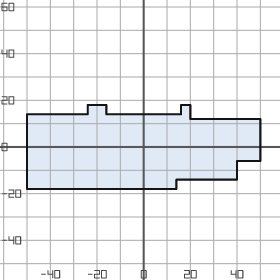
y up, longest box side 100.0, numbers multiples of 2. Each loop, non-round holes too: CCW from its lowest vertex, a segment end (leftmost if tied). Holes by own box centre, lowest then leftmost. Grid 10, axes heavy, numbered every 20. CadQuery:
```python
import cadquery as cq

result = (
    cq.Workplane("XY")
    .moveTo(-50.0, -18.0)
    .lineTo(14.0, -18.0)
    .lineTo(14.0, -14.0)
    .lineTo(40.0, -14.0)
    .lineTo(40.0, -6.0)
    .lineTo(50.0, -6.0)
    .lineTo(50.0, 12.0)
    .lineTo(20.0, 12.0)
    .lineTo(20.0, 18.0)
    .lineTo(16.0, 18.0)
    .lineTo(16.0, 14.0)
    .lineTo(-16.0, 14.0)
    .lineTo(-16.0, 18.0)
    .lineTo(-24.0, 18.0)
    .lineTo(-24.0, 14.0)
    .lineTo(-50.0, 14.0)
    .close()
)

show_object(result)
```